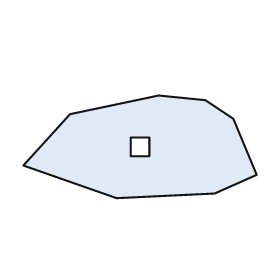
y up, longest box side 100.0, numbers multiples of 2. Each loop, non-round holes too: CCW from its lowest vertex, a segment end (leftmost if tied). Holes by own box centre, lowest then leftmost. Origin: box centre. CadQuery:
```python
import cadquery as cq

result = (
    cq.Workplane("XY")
    .moveTo(-10.0, -22.0)
    .lineTo(32.0, -20.0)
    .lineTo(50.0, -12.0)
    .lineTo(40.0, 12.0)
    .lineTo(28.0, 20.0)
    .lineTo(8.0, 22.0)
    .lineTo(-30.0, 14.0)
    .lineTo(-50.0, -8.0)
    .close()
    .moveTo(-4.0, -4.0)
    .lineTo(4.0, -4.0)
    .lineTo(4.0, 4.0)
    .lineTo(-4.0, 4.0)
    .close()
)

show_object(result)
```